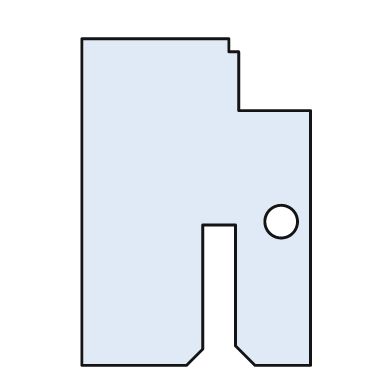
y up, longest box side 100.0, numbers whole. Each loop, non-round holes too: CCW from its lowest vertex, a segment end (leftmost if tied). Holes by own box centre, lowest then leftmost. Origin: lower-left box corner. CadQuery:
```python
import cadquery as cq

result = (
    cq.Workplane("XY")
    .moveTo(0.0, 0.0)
    .lineTo(32.0, 0.0)
    .lineTo(37.0, 5.0)
    .lineTo(37.0, 43.0)
    .lineTo(47.0, 43.0)
    .lineTo(47.0, 6.0)
    .lineTo(53.0, 0.0)
    .lineTo(70.0, 0.0)
    .lineTo(70.0, 78.0)
    .lineTo(48.0, 78.0)
    .lineTo(48.0, 96.0)
    .lineTo(45.0, 96.0)
    .lineTo(45.0, 100.0)
    .lineTo(0.0, 100.0)
    .close()
    .moveTo(61.0, 44.0)
    .circle(5.0)
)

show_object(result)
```